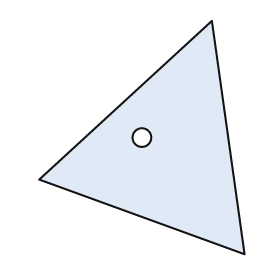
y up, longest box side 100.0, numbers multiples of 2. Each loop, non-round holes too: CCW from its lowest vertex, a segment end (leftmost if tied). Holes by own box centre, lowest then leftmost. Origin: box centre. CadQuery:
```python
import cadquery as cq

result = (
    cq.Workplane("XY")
    .moveTo(44.0, -50.0)
    .lineTo(30.0, 50.0)
    .lineTo(-44.0, -18.0)
    .close()
    .moveTo(0.0, 0.0)
    .circle(4.0)
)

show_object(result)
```